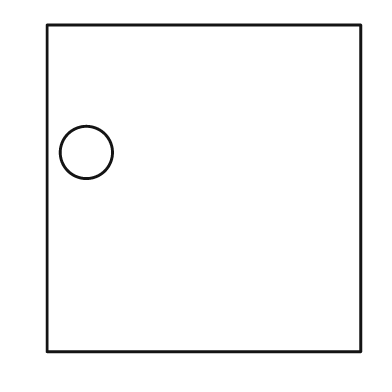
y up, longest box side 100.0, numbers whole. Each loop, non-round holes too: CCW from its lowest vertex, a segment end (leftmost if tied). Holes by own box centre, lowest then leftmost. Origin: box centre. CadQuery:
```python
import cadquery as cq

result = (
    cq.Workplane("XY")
    .moveTo(-48.0, -50.0)
    .lineTo(48.0, -50.0)
    .lineTo(48.0, 50.0)
    .lineTo(-48.0, 50.0)
    .close()
    .moveTo(-36.0, 11.0)
    .circle(8.0)
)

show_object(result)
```